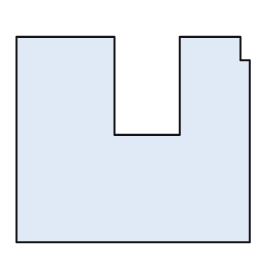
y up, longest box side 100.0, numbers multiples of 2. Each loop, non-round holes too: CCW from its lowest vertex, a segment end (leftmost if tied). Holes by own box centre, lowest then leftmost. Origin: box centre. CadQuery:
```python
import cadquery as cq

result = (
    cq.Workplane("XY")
    .moveTo(-50.0, -44.0)
    .lineTo(50.0, -44.0)
    .lineTo(50.0, 34.0)
    .lineTo(46.0, 34.0)
    .lineTo(46.0, 44.0)
    .lineTo(20.0, 44.0)
    .lineTo(20.0, 2.0)
    .lineTo(-8.0, 2.0)
    .lineTo(-8.0, 44.0)
    .lineTo(-50.0, 44.0)
    .close()
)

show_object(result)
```